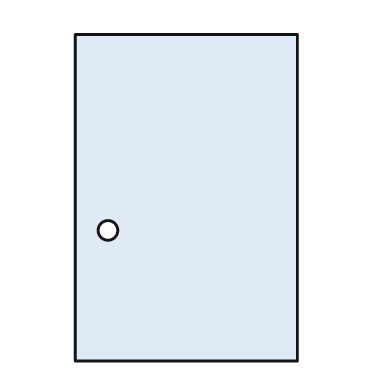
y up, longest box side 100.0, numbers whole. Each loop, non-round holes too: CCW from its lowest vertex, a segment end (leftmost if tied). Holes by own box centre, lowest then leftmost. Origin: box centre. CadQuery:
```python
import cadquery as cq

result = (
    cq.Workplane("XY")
    .moveTo(-34.0, -50.0)
    .lineTo(34.0, -50.0)
    .lineTo(34.0, 50.0)
    .lineTo(-34.0, 50.0)
    .close()
    .moveTo(-24.0, -10.0)
    .circle(3.0)
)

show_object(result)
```